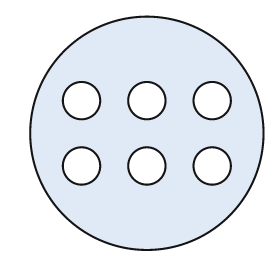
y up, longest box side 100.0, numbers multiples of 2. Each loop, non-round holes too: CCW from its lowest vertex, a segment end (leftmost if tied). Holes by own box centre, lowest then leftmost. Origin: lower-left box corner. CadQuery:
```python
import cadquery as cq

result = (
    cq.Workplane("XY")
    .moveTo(50.0, 50.0)
    .circle(50.0)
    .moveTo(22.0, 36.0)
    .circle(8.0)
    .moveTo(50.0, 36.0)
    .circle(8.0)
    .moveTo(78.0, 36.0)
    .circle(8.0)
    .moveTo(22.0, 64.0)
    .circle(8.0)
    .moveTo(50.0, 64.0)
    .circle(8.0)
    .moveTo(78.0, 64.0)
    .circle(8.0)
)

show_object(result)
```